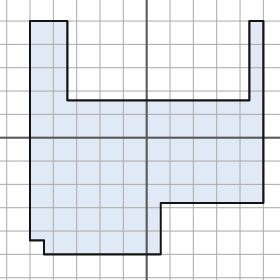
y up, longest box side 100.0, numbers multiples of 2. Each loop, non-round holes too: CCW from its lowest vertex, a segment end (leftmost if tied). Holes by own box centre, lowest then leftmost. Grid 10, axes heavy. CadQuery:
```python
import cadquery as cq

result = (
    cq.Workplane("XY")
    .moveTo(-44.0, -50.0)
    .lineTo(6.0, -50.0)
    .lineTo(6.0, -28.0)
    .lineTo(50.0, -28.0)
    .lineTo(50.0, 50.0)
    .lineTo(44.0, 50.0)
    .lineTo(44.0, 16.0)
    .lineTo(-34.0, 16.0)
    .lineTo(-34.0, 50.0)
    .lineTo(-50.0, 50.0)
    .lineTo(-50.0, -44.0)
    .lineTo(-44.0, -44.0)
    .close()
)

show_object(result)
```